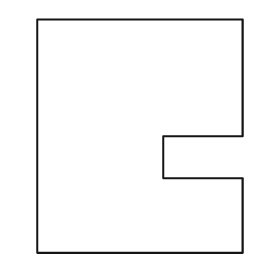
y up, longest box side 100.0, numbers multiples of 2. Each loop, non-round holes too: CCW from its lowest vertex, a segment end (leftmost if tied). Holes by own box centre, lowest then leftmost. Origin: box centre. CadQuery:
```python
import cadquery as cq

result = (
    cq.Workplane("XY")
    .moveTo(-44.0, -50.0)
    .lineTo(44.0, -50.0)
    .lineTo(44.0, -18.0)
    .lineTo(10.0, -18.0)
    .lineTo(10.0, 0.0)
    .lineTo(44.0, 0.0)
    .lineTo(44.0, 50.0)
    .lineTo(-44.0, 50.0)
    .close()
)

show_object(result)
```